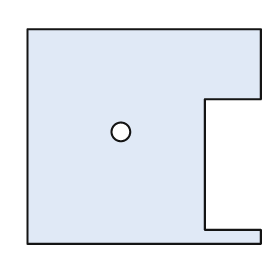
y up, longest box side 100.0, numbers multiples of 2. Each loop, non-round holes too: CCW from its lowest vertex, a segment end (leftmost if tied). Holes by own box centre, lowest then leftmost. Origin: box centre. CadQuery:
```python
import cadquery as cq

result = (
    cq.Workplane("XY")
    .moveTo(-50.0, -46.0)
    .lineTo(50.0, -46.0)
    .lineTo(50.0, -40.0)
    .lineTo(26.0, -40.0)
    .lineTo(26.0, 16.0)
    .lineTo(50.0, 16.0)
    .lineTo(50.0, 46.0)
    .lineTo(-50.0, 46.0)
    .close()
    .moveTo(-10.0, 2.0)
    .circle(4.0)
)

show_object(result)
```